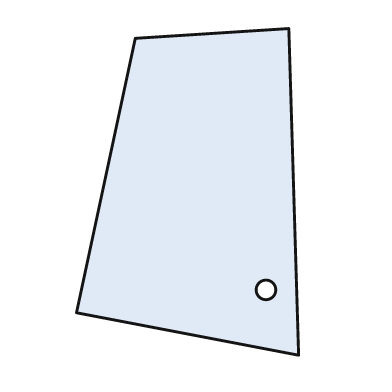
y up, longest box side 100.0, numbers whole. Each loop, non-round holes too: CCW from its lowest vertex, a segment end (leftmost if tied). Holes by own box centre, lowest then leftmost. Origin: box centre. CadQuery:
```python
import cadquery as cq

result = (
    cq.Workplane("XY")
    .moveTo(34.0, -50.0)
    .lineTo(31.0, 50.0)
    .lineTo(-16.0, 47.0)
    .lineTo(-34.0, -37.0)
    .close()
    .moveTo(24.0, -30.0)
    .circle(3.0)
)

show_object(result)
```